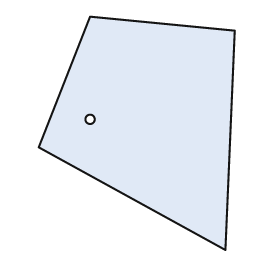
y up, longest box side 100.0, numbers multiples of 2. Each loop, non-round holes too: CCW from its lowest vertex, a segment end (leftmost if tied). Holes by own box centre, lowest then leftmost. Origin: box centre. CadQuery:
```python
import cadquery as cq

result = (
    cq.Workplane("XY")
    .moveTo(38.0, -50.0)
    .lineTo(42.0, 44.0)
    .lineTo(-20.0, 50.0)
    .lineTo(-42.0, -6.0)
    .close()
    .moveTo(-20.0, 6.0)
    .circle(2.0)
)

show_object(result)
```